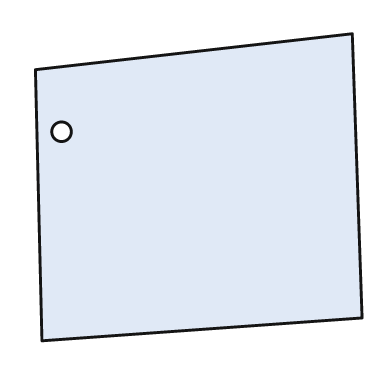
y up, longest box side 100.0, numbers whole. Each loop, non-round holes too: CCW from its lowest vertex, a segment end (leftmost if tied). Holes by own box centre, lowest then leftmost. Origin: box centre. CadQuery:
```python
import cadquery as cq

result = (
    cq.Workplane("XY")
    .moveTo(-48.0, -47.0)
    .lineTo(50.0, -40.0)
    .lineTo(47.0, 47.0)
    .lineTo(-50.0, 36.0)
    .close()
    .moveTo(-42.0, 17.0)
    .circle(3.0)
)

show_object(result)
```